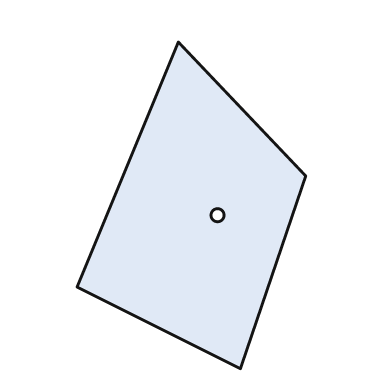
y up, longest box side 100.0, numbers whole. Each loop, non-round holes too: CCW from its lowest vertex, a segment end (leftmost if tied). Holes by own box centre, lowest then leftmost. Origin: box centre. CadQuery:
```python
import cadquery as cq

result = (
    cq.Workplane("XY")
    .moveTo(15.0, -50.0)
    .lineTo(35.0, 9.0)
    .lineTo(-4.0, 50.0)
    .lineTo(-35.0, -25.0)
    .close()
    .moveTo(8.0, -3.0)
    .circle(2.0)
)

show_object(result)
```